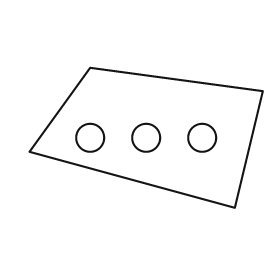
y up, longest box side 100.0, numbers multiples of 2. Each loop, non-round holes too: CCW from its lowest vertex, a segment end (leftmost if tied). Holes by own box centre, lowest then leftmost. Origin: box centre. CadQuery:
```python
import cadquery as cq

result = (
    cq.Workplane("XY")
    .moveTo(38.0, -30.0)
    .lineTo(50.0, 20.0)
    .lineTo(-24.0, 30.0)
    .lineTo(-50.0, -6.0)
    .close()
    .moveTo(-24.0, 0.0)
    .circle(6.0)
    .moveTo(0.0, 0.0)
    .circle(6.0)
    .moveTo(24.0, 0.0)
    .circle(6.0)
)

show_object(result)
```